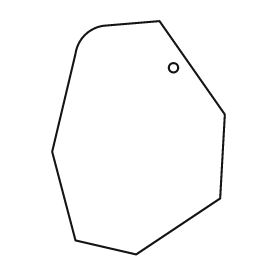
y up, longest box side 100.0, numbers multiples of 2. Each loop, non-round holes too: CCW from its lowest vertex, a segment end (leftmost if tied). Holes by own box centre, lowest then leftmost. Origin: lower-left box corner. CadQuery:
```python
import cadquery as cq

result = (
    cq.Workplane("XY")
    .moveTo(36.0, 0.0)
    .lineTo(72.0, 24.0)
    .lineTo(74.0, 60.0)
    .lineTo(46.0, 100.0)
    .lineTo(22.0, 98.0)
    .threePointArc((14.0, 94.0), (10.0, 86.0))
    .lineTo(0.0, 44.0)
    .lineTo(10.0, 6.0)
    .close()
    .moveTo(52.0, 80.0)
    .circle(2.0)
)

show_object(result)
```